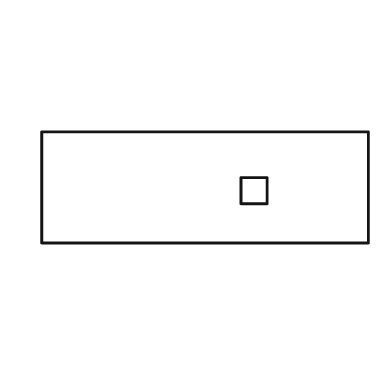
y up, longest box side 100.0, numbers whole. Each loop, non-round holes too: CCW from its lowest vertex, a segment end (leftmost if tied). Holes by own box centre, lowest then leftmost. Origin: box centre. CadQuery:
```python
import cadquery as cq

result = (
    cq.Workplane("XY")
    .moveTo(-50.0, -17.0)
    .lineTo(50.0, -17.0)
    .lineTo(50.0, 17.0)
    .lineTo(-50.0, 17.0)
    .close()
    .moveTo(11.0, -5.0)
    .lineTo(19.0, -5.0)
    .lineTo(19.0, 3.0)
    .lineTo(11.0, 3.0)
    .close()
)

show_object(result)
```